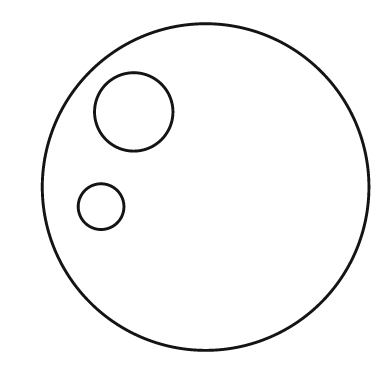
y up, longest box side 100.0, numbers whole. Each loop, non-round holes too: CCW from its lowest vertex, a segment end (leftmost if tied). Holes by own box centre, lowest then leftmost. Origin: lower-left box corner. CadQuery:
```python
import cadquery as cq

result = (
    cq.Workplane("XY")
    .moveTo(50.0, 50.0)
    .circle(50.0)
    .moveTo(18.0, 44.0)
    .circle(7.0)
    .moveTo(28.0, 73.0)
    .circle(12.0)
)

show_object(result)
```